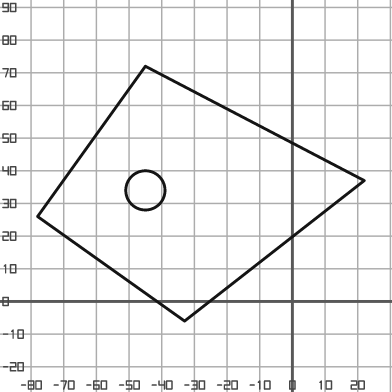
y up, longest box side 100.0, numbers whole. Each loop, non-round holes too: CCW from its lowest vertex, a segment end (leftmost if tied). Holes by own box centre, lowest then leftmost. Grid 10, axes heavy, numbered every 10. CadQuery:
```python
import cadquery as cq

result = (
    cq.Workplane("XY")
    .moveTo(-33.0, -6.0)
    .lineTo(22.0, 37.0)
    .lineTo(-45.0, 72.0)
    .lineTo(-78.0, 26.0)
    .close()
    .moveTo(-45.0, 34.0)
    .circle(6.0)
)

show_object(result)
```